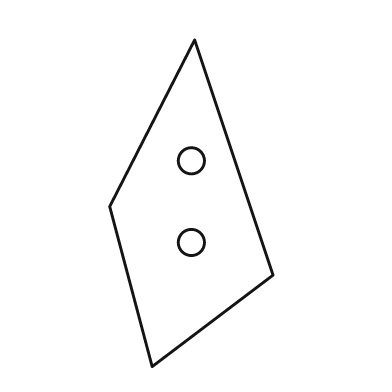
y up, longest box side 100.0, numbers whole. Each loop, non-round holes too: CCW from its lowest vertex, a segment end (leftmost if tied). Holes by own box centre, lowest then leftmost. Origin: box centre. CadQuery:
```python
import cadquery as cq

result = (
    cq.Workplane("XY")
    .moveTo(-12.0, -50.0)
    .lineTo(25.0, -22.0)
    .lineTo(1.0, 50.0)
    .lineTo(-25.0, -1.0)
    .close()
    .moveTo(0.0, -12.0)
    .circle(4.0)
    .moveTo(0.0, 13.0)
    .circle(4.0)
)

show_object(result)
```